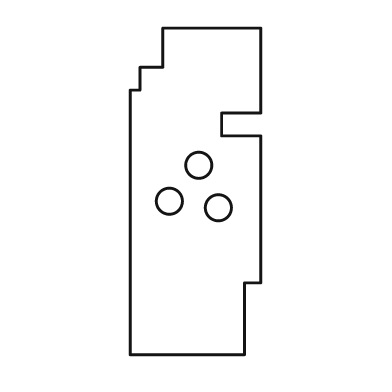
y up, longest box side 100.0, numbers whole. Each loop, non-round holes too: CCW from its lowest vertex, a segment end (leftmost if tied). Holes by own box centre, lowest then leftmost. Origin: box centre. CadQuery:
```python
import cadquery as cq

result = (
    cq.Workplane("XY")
    .moveTo(-20.0, -50.0)
    .lineTo(15.0, -50.0)
    .lineTo(15.0, -28.0)
    .lineTo(20.0, -28.0)
    .lineTo(20.0, 17.0)
    .lineTo(8.0, 17.0)
    .lineTo(8.0, 24.0)
    .lineTo(20.0, 24.0)
    .lineTo(20.0, 50.0)
    .lineTo(-10.0, 50.0)
    .lineTo(-10.0, 38.0)
    .lineTo(-17.0, 38.0)
    .lineTo(-17.0, 31.0)
    .lineTo(-20.0, 31.0)
    .close()
    .moveTo(7.0, -5.0)
    .circle(4.0)
    .moveTo(-8.0, -3.0)
    .circle(4.0)
    .moveTo(1.0, 8.0)
    .circle(4.0)
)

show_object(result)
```